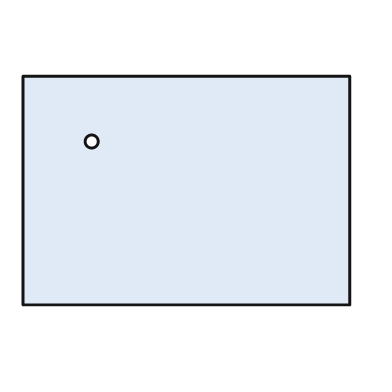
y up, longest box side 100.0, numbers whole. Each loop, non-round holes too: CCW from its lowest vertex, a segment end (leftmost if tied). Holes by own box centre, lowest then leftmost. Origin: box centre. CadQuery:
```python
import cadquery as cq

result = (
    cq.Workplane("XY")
    .moveTo(-50.0, -35.0)
    .lineTo(50.0, -35.0)
    .lineTo(50.0, 35.0)
    .lineTo(-50.0, 35.0)
    .close()
    .moveTo(-29.0, 15.0)
    .circle(2.0)
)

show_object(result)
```